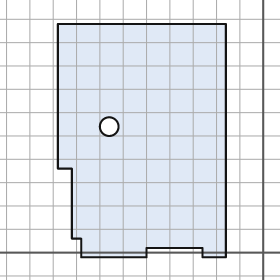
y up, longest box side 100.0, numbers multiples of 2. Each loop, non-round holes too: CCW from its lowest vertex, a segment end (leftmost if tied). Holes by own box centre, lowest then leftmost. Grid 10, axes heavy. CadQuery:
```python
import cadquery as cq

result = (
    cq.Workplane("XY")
    .moveTo(-78.0, -2.0)
    .lineTo(-50.0, -2.0)
    .lineTo(-50.0, 2.0)
    .lineTo(-26.0, 2.0)
    .lineTo(-26.0, -2.0)
    .lineTo(-16.0, -2.0)
    .lineTo(-16.0, 98.0)
    .lineTo(-88.0, 98.0)
    .lineTo(-88.0, 36.0)
    .lineTo(-82.0, 36.0)
    .lineTo(-82.0, 6.0)
    .lineTo(-78.0, 6.0)
    .close()
    .moveTo(-66.0, 54.0)
    .circle(4.0)
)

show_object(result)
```